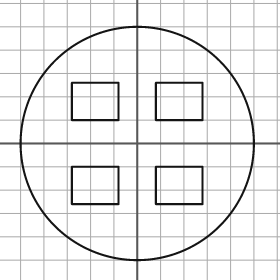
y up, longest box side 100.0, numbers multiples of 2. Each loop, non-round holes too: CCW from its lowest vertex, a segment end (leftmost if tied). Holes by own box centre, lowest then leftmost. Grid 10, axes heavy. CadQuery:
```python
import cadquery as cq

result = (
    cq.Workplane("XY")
    .moveTo(0.0, 0.0)
    .circle(50.0)
    .moveTo(-28.0, -26.0)
    .lineTo(-8.0, -26.0)
    .lineTo(-8.0, -10.0)
    .lineTo(-28.0, -10.0)
    .close()
    .moveTo(8.0, -26.0)
    .lineTo(28.0, -26.0)
    .lineTo(28.0, -10.0)
    .lineTo(8.0, -10.0)
    .close()
    .moveTo(-28.0, 10.0)
    .lineTo(-8.0, 10.0)
    .lineTo(-8.0, 26.0)
    .lineTo(-28.0, 26.0)
    .close()
    .moveTo(8.0, 10.0)
    .lineTo(28.0, 10.0)
    .lineTo(28.0, 26.0)
    .lineTo(8.0, 26.0)
    .close()
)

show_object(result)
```